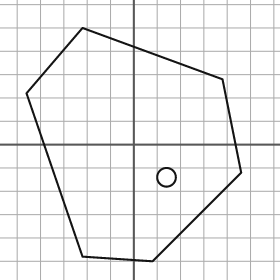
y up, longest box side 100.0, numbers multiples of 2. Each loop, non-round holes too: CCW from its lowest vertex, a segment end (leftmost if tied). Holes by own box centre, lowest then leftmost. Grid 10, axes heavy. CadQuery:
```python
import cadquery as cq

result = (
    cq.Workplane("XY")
    .moveTo(8.0, -50.0)
    .lineTo(46.0, -12.0)
    .lineTo(38.0, 28.0)
    .lineTo(-22.0, 50.0)
    .lineTo(-46.0, 22.0)
    .lineTo(-22.0, -48.0)
    .close()
    .moveTo(14.0, -14.0)
    .circle(4.0)
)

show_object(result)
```